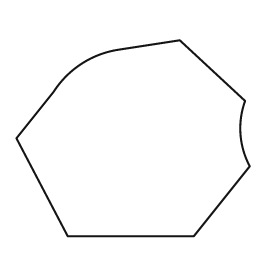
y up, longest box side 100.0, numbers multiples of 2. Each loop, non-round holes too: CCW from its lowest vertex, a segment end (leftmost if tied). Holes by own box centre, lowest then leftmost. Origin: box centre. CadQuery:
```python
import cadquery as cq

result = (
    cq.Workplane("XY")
    .moveTo(-28.0, -42.0)
    .lineTo(26.0, -42.0)
    .lineTo(50.0, -12.0)
    .threePointArc((46.0, 2.0), (48.0, 16.0))
    .lineTo(20.0, 42.0)
    .lineTo(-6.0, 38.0)
    .threePointArc((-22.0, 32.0), (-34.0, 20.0))
    .lineTo(-50.0, 0.0)
    .close()
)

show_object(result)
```